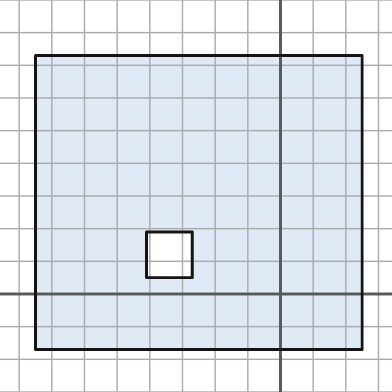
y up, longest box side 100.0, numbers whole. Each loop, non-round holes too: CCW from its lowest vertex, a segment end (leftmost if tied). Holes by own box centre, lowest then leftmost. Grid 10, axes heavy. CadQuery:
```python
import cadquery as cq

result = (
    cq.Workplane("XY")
    .moveTo(-75.0, -17.0)
    .lineTo(25.0, -17.0)
    .lineTo(25.0, 73.0)
    .lineTo(-75.0, 73.0)
    .close()
    .moveTo(-41.0, 5.0)
    .lineTo(-27.0, 5.0)
    .lineTo(-27.0, 19.0)
    .lineTo(-41.0, 19.0)
    .close()
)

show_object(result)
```